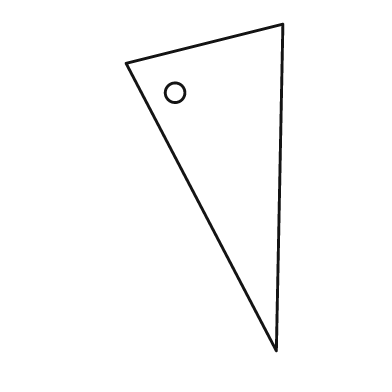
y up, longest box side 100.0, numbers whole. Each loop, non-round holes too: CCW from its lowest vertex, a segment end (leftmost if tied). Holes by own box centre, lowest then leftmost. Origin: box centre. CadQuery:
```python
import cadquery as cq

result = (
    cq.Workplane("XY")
    .moveTo(22.0, -50.0)
    .lineTo(24.0, 50.0)
    .lineTo(-24.0, 38.0)
    .close()
    .moveTo(-9.0, 29.0)
    .circle(3.0)
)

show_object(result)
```